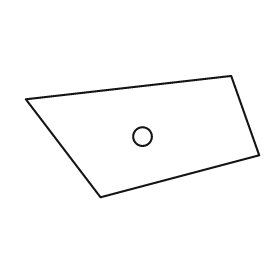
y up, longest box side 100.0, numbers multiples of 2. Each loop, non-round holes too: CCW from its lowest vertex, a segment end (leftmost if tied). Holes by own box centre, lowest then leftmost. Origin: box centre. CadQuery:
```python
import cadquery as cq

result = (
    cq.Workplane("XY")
    .moveTo(-18.0, -26.0)
    .lineTo(50.0, -8.0)
    .lineTo(38.0, 26.0)
    .lineTo(-50.0, 16.0)
    .close()
    .moveTo(0.0, 0.0)
    .circle(4.0)
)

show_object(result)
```